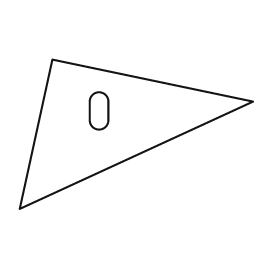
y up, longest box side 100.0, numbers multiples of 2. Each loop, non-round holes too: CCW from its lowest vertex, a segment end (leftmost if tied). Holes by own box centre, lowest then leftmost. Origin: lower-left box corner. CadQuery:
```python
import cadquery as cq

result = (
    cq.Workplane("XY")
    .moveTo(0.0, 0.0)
    .lineTo(100.0, 46.0)
    .lineTo(14.0, 64.0)
    .close()
    .moveTo(30.0, 38.0)
    .threePointArc((34.0, 34.0), (38.0, 38.0))
    .lineTo(38.0, 46.0)
    .threePointArc((34.0, 50.0), (30.0, 46.0))
    .close()
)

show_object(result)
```